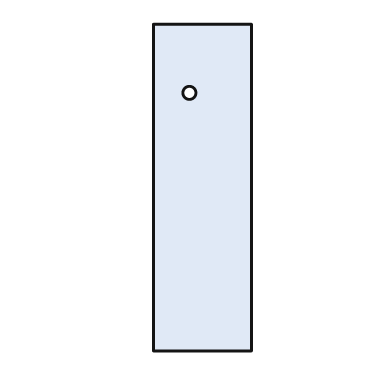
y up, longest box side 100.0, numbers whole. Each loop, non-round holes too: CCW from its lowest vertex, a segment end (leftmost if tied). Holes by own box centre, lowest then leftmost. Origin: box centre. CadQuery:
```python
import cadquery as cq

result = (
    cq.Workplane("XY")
    .moveTo(-15.0, -50.0)
    .lineTo(15.0, -50.0)
    .lineTo(15.0, 50.0)
    .lineTo(-15.0, 50.0)
    .close()
    .moveTo(-4.0, 29.0)
    .circle(2.0)
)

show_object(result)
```